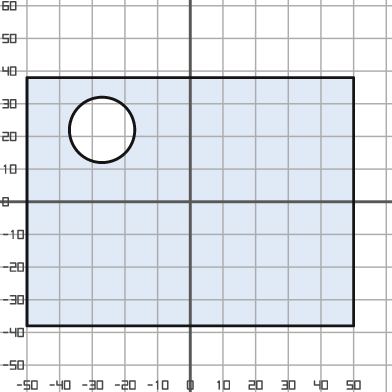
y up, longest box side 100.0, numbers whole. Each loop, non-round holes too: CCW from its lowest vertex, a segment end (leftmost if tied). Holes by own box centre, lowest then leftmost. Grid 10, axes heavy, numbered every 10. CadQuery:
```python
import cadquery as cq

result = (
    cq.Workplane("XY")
    .moveTo(-50.0, -38.0)
    .lineTo(50.0, -38.0)
    .lineTo(50.0, 38.0)
    .lineTo(-50.0, 38.0)
    .close()
    .moveTo(-27.0, 22.0)
    .circle(10.0)
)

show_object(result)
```